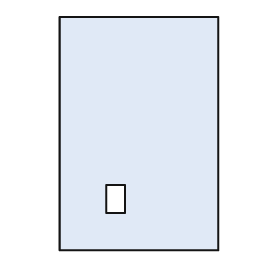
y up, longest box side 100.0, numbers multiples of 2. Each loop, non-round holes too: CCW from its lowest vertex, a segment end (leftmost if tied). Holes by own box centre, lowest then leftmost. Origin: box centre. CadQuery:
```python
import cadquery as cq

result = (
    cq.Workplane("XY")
    .moveTo(-34.0, -50.0)
    .lineTo(34.0, -50.0)
    .lineTo(34.0, 50.0)
    .lineTo(-34.0, 50.0)
    .close()
    .moveTo(-14.0, -34.0)
    .lineTo(-6.0, -34.0)
    .lineTo(-6.0, -22.0)
    .lineTo(-14.0, -22.0)
    .close()
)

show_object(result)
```